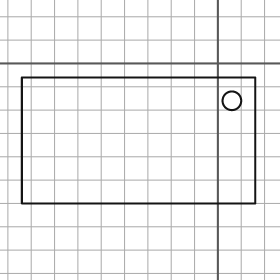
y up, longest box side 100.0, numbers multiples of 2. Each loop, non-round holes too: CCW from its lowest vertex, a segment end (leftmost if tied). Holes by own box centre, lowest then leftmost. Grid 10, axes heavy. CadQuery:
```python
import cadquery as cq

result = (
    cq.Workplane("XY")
    .moveTo(-84.0, -60.0)
    .lineTo(16.0, -60.0)
    .lineTo(16.0, -6.0)
    .lineTo(-84.0, -6.0)
    .close()
    .moveTo(6.0, -16.0)
    .circle(4.0)
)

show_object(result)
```